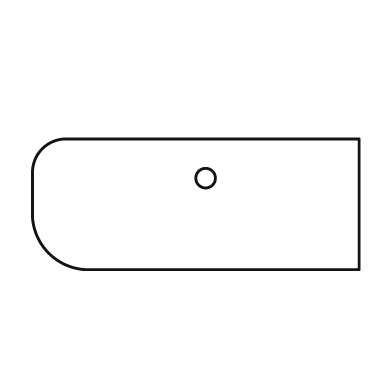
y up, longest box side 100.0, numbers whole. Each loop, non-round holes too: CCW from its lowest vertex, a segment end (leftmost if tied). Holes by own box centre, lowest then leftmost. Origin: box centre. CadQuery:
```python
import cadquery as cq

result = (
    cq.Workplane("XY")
    .moveTo(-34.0, -20.0)
    .lineTo(50.0, -20.0)
    .lineTo(50.0, 20.0)
    .lineTo(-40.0, 20.0)
    .threePointArc((-47.0, 17.0), (-50.0, 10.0))
    .lineTo(-50.0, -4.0)
    .threePointArc((-45.0, -15.0), (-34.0, -20.0))
    .close()
    .moveTo(3.0, 8.0)
    .circle(3.0)
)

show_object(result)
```